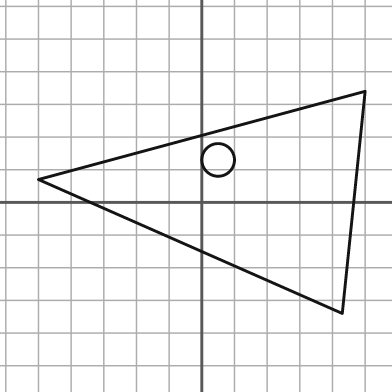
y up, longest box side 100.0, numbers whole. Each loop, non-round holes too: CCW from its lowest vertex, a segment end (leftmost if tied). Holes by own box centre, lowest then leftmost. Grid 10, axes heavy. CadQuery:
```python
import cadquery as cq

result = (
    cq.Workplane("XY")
    .moveTo(43.0, -34.0)
    .lineTo(50.0, 34.0)
    .lineTo(-50.0, 7.0)
    .close()
    .moveTo(5.0, 13.0)
    .circle(5.0)
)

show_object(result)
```